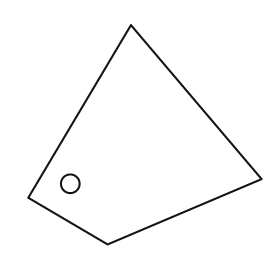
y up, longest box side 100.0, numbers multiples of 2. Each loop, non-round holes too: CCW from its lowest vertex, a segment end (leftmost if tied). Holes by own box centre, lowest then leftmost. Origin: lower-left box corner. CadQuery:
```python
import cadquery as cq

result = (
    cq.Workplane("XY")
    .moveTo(34.0, 0.0)
    .lineTo(100.0, 28.0)
    .lineTo(44.0, 94.0)
    .lineTo(0.0, 20.0)
    .close()
    .moveTo(18.0, 26.0)
    .circle(4.0)
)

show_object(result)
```